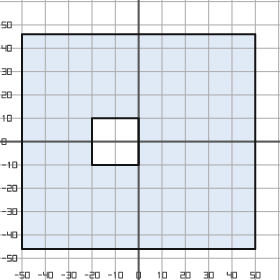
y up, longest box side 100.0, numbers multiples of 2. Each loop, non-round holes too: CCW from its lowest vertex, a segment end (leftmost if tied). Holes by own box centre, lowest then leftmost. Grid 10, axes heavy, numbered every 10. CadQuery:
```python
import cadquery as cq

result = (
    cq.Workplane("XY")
    .moveTo(-50.0, -46.0)
    .lineTo(50.0, -46.0)
    .lineTo(50.0, 46.0)
    .lineTo(-50.0, 46.0)
    .close()
    .moveTo(-20.0, -10.0)
    .lineTo(0.0, -10.0)
    .lineTo(0.0, 10.0)
    .lineTo(-20.0, 10.0)
    .close()
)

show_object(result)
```